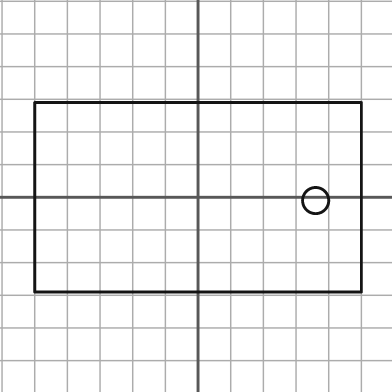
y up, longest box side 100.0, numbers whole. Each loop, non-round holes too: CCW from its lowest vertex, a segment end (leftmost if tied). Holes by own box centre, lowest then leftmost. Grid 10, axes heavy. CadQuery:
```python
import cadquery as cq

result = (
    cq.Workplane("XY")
    .moveTo(-50.0, -29.0)
    .lineTo(50.0, -29.0)
    .lineTo(50.0, 29.0)
    .lineTo(-50.0, 29.0)
    .close()
    .moveTo(36.0, -1.0)
    .circle(4.0)
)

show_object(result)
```